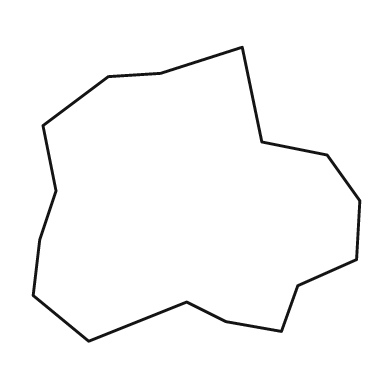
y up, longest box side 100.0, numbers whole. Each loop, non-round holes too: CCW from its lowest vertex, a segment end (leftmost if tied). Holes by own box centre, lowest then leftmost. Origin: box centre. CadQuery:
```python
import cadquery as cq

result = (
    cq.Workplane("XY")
    .moveTo(-33.0, -45.0)
    .lineTo(-3.0, -33.0)
    .lineTo(9.0, -39.0)
    .lineTo(26.0, -42.0)
    .lineTo(31.0, -28.0)
    .lineTo(49.0, -20.0)
    .lineTo(50.0, -2.0)
    .lineTo(40.0, 12.0)
    .lineTo(20.0, 16.0)
    .lineTo(14.0, 45.0)
    .lineTo(-11.0, 37.0)
    .lineTo(-27.0, 36.0)
    .lineTo(-47.0, 21.0)
    .lineTo(-43.0, 1.0)
    .lineTo(-48.0, -14.0)
    .lineTo(-50.0, -31.0)
    .close()
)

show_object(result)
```